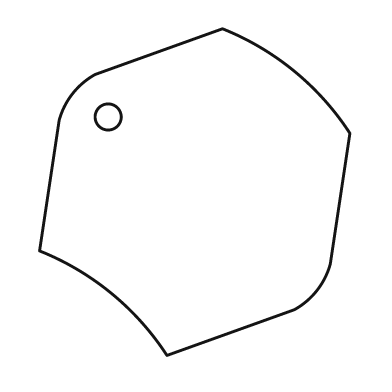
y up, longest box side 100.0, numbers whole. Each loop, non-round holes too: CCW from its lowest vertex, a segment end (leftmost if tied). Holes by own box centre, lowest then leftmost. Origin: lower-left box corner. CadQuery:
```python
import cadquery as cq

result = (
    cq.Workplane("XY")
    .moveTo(39.0, 0.0)
    .lineTo(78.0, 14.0)
    .threePointArc((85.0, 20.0), (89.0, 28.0))
    .lineTo(95.0, 68.0)
    .threePointArc((78.0, 87.0), (56.0, 100.0))
    .lineTo(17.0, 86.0)
    .threePointArc((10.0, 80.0), (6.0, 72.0))
    .lineTo(0.0, 32.0)
    .threePointArc((22.0, 19.0), (39.0, 0.0))
    .close()
    .moveTo(21.0, 73.0)
    .circle(4.0)
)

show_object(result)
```